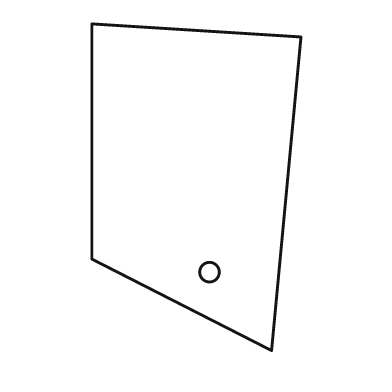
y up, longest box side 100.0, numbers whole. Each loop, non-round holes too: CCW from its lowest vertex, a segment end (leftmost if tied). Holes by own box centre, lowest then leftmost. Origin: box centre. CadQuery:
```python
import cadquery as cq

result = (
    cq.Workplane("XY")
    .moveTo(23.0, -50.0)
    .lineTo(32.0, 46.0)
    .lineTo(-32.0, 50.0)
    .lineTo(-32.0, -22.0)
    .close()
    .moveTo(4.0, -26.0)
    .circle(3.0)
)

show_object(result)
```